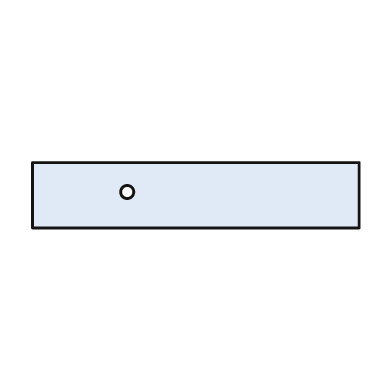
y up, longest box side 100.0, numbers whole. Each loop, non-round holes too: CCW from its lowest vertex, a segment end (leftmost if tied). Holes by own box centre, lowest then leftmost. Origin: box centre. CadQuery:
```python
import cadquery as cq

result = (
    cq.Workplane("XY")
    .moveTo(-50.0, -10.0)
    .lineTo(50.0, -10.0)
    .lineTo(50.0, 10.0)
    .lineTo(-50.0, 10.0)
    .close()
    .moveTo(-21.0, 1.0)
    .circle(2.0)
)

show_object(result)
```